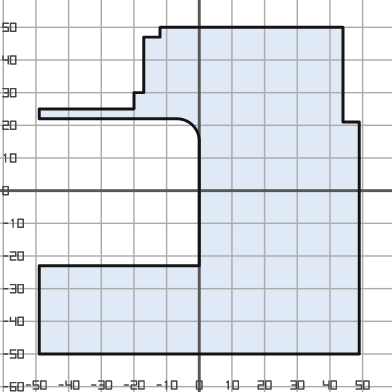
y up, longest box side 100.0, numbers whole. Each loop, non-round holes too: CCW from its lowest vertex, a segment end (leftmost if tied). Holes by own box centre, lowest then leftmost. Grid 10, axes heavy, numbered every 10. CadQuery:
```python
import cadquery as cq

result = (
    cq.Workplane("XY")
    .moveTo(-49.0, -50.0)
    .lineTo(49.0, -50.0)
    .lineTo(49.0, 21.0)
    .lineTo(44.0, 21.0)
    .lineTo(44.0, 50.0)
    .lineTo(-12.0, 50.0)
    .lineTo(-12.0, 47.0)
    .lineTo(-17.0, 47.0)
    .lineTo(-17.0, 30.0)
    .lineTo(-20.0, 30.0)
    .lineTo(-20.0, 25.0)
    .lineTo(-49.0, 25.0)
    .lineTo(-49.0, 22.0)
    .lineTo(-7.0, 22.0)
    .threePointArc((-2.0, 20.0), (0.0, 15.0))
    .lineTo(0.0, -23.0)
    .lineTo(-49.0, -23.0)
    .close()
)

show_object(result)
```